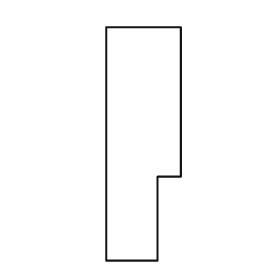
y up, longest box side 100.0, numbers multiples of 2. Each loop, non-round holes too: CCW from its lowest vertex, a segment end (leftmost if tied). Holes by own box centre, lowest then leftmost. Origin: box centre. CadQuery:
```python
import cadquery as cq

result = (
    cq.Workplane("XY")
    .moveTo(-16.0, -50.0)
    .lineTo(6.0, -50.0)
    .lineTo(6.0, -14.0)
    .lineTo(16.0, -14.0)
    .lineTo(16.0, 50.0)
    .lineTo(-16.0, 50.0)
    .close()
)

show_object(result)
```